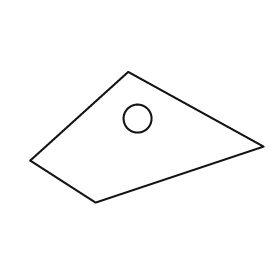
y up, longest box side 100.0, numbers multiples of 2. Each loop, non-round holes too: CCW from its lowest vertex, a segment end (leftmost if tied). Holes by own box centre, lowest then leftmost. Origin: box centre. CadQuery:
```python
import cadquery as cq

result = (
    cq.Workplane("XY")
    .moveTo(-22.0, -28.0)
    .lineTo(50.0, -4.0)
    .lineTo(-8.0, 28.0)
    .lineTo(-50.0, -10.0)
    .close()
    .moveTo(-4.0, 8.0)
    .circle(6.0)
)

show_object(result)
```